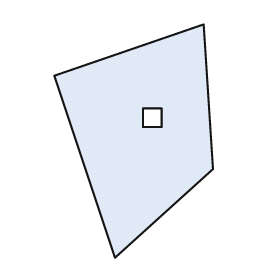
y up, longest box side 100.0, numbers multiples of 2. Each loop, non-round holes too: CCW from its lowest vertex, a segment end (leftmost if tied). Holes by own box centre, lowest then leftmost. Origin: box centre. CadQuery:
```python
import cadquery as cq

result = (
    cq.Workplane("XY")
    .moveTo(-8.0, -50.0)
    .lineTo(34.0, -12.0)
    .lineTo(30.0, 50.0)
    .lineTo(-34.0, 28.0)
    .close()
    .moveTo(4.0, 6.0)
    .lineTo(12.0, 6.0)
    .lineTo(12.0, 14.0)
    .lineTo(4.0, 14.0)
    .close()
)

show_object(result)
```